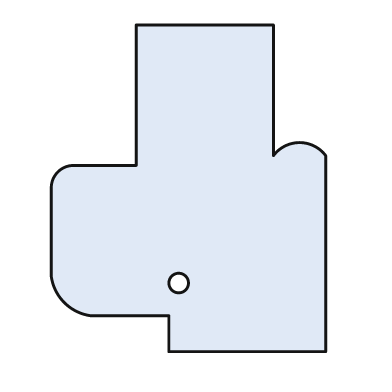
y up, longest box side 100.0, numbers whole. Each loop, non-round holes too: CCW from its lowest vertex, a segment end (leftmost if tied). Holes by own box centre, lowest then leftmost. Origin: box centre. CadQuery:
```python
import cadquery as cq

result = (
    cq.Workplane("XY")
    .moveTo(-6.0, -50.0)
    .lineTo(42.0, -50.0)
    .lineTo(42.0, 10.0)
    .threePointArc((34.0, 14.0), (26.0, 10.0))
    .lineTo(26.0, 50.0)
    .lineTo(-16.0, 50.0)
    .lineTo(-16.0, 7.0)
    .lineTo(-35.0, 7.0)
    .threePointArc((-40.0, 5.0), (-42.0, 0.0))
    .lineTo(-42.0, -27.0)
    .threePointArc((-38.0, -35.0), (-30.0, -39.0))
    .lineTo(-6.0, -39.0)
    .close()
    .moveTo(-3.0, -29.0)
    .circle(3.0)
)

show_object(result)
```